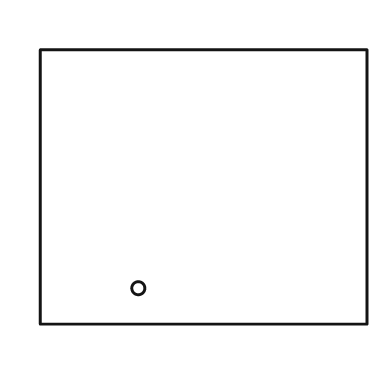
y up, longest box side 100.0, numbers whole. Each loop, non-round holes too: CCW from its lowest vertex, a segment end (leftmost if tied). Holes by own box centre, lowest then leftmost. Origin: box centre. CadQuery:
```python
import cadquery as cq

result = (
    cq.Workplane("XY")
    .moveTo(-50.0, -42.0)
    .lineTo(50.0, -42.0)
    .lineTo(50.0, 42.0)
    .lineTo(-50.0, 42.0)
    .close()
    .moveTo(-20.0, -31.0)
    .circle(2.0)
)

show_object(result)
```